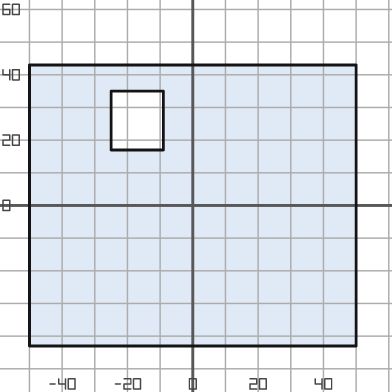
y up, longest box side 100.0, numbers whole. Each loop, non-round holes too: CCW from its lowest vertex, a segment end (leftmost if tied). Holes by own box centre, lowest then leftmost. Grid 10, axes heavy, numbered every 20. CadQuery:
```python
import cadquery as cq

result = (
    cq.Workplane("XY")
    .moveTo(-50.0, -43.0)
    .lineTo(50.0, -43.0)
    .lineTo(50.0, 43.0)
    .lineTo(-50.0, 43.0)
    .close()
    .moveTo(-25.0, 17.0)
    .lineTo(-9.0, 17.0)
    .lineTo(-9.0, 35.0)
    .lineTo(-25.0, 35.0)
    .close()
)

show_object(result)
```